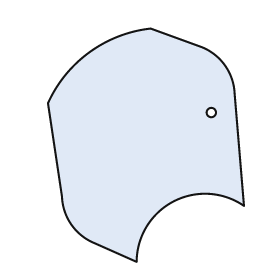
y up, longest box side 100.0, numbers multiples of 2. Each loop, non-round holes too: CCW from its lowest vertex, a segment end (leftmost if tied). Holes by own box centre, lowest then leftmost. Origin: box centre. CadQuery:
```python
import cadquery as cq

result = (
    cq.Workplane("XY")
    .moveTo(-4.0, -50.0)
    .threePointArc((12.0, -24.0), (42.0, -26.0))
    .lineTo(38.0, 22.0)
    .threePointArc((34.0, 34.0), (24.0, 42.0))
    .lineTo(2.0, 50.0)
    .threePointArc((-24.0, 40.0), (-42.0, 18.0))
    .lineTo(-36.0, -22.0)
    .threePointArc((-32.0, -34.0), (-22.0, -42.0))
    .close()
    .moveTo(28.0, 14.0)
    .circle(2.0)
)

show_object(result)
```